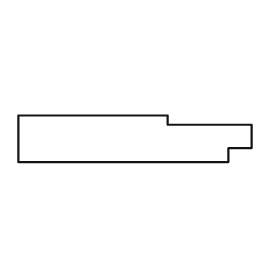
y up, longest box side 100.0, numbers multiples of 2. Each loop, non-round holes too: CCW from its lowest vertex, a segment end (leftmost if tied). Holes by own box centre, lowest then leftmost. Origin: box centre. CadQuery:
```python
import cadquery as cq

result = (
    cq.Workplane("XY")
    .moveTo(-50.0, -10.0)
    .lineTo(40.0, -10.0)
    .lineTo(40.0, -4.0)
    .lineTo(50.0, -4.0)
    .lineTo(50.0, 6.0)
    .lineTo(14.0, 6.0)
    .lineTo(14.0, 10.0)
    .lineTo(-50.0, 10.0)
    .close()
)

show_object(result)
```